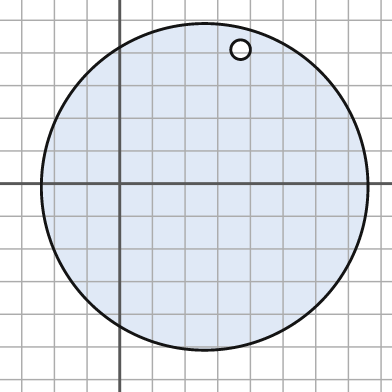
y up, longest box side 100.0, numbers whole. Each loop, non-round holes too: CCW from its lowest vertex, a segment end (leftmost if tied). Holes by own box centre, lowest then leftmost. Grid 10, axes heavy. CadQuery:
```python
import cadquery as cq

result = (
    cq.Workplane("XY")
    .moveTo(26.0, -1.0)
    .circle(50.0)
    .moveTo(37.0, 41.0)
    .circle(3.0)
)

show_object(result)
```